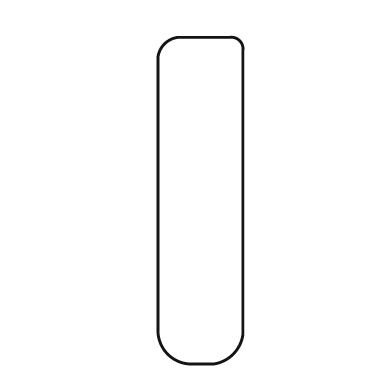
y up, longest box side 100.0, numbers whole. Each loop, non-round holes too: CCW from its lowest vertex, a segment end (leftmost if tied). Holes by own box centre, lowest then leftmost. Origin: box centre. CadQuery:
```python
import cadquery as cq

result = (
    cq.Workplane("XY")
    .moveTo(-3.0, -50.0)
    .lineTo(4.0, -50.0)
    .threePointArc((10.0, -47.0), (13.0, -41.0))
    .lineTo(13.0, 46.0)
    .threePointArc((12.0, 49.0), (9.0, 50.0))
    .lineTo(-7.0, 50.0)
    .threePointArc((-11.0, 48.0), (-13.0, 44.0))
    .lineTo(-13.0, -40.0)
    .threePointArc((-10.0, -47.0), (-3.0, -50.0))
    .close()
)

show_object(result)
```